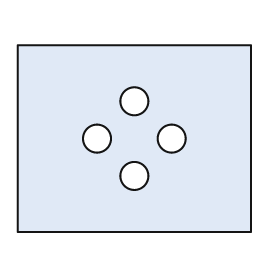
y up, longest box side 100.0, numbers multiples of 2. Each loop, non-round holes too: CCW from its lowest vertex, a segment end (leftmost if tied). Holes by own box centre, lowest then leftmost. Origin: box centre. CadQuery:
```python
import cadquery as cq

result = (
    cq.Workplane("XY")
    .moveTo(-50.0, -40.0)
    .lineTo(50.0, -40.0)
    .lineTo(50.0, 40.0)
    .lineTo(-50.0, 40.0)
    .close()
    .moveTo(0.0, -16.0)
    .circle(6.0)
    .moveTo(-16.0, 0.0)
    .circle(6.0)
    .moveTo(16.0, 0.0)
    .circle(6.0)
    .moveTo(0.0, 16.0)
    .circle(6.0)
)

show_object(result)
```